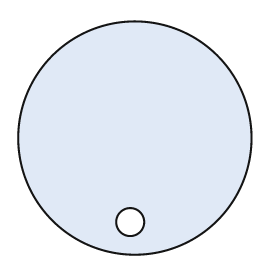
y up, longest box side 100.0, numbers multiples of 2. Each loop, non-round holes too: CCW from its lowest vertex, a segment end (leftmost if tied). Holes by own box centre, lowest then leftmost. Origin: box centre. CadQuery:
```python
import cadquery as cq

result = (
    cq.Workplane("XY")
    .moveTo(0.0, 0.0)
    .circle(50.0)
    .moveTo(-2.0, -36.0)
    .circle(6.0)
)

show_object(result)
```